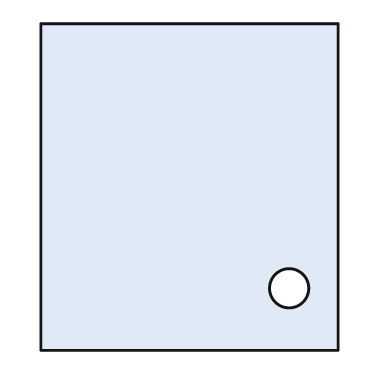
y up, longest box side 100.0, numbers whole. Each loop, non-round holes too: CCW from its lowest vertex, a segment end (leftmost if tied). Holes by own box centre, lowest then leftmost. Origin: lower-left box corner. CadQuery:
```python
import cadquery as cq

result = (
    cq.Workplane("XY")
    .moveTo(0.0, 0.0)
    .lineTo(91.0, 0.0)
    .lineTo(91.0, 100.0)
    .lineTo(0.0, 100.0)
    .close()
    .moveTo(76.0, 19.0)
    .circle(6.0)
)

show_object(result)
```